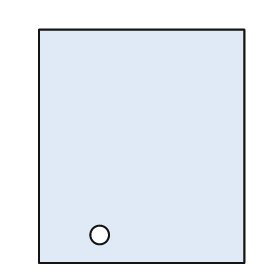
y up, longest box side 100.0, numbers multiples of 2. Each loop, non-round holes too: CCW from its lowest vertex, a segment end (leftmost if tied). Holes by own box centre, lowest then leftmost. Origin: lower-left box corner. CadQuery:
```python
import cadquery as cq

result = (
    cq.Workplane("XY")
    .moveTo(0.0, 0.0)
    .lineTo(88.0, 0.0)
    .lineTo(88.0, 100.0)
    .lineTo(0.0, 100.0)
    .close()
    .moveTo(26.0, 12.0)
    .circle(4.0)
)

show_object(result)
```